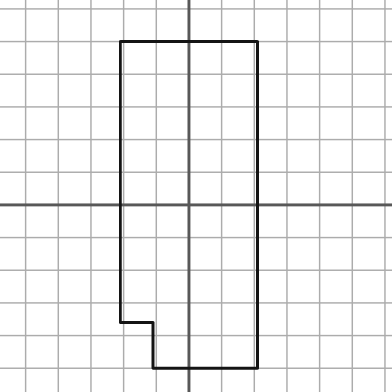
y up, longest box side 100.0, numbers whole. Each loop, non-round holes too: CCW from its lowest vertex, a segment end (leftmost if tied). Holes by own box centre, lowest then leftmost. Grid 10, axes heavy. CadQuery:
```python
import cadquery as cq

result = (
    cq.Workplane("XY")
    .moveTo(-11.0, -50.0)
    .lineTo(21.0, -50.0)
    .lineTo(21.0, 50.0)
    .lineTo(-21.0, 50.0)
    .lineTo(-21.0, -36.0)
    .lineTo(-11.0, -36.0)
    .close()
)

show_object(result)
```